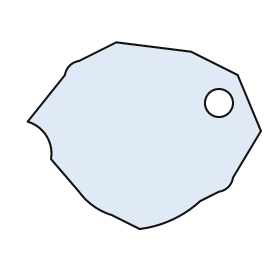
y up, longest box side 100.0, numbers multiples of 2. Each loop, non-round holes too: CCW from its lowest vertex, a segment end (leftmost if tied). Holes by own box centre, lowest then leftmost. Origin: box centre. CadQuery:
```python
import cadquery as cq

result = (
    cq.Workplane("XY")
    .moveTo(-2.0, -40.0)
    .threePointArc((12.0, -36.0), (24.0, -28.0))
    .lineTo(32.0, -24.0)
    .threePointArc((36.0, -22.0), (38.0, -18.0))
    .lineTo(50.0, 2.0)
    .lineTo(40.0, 26.0)
    .lineTo(20.0, 36.0)
    .lineTo(-12.0, 40.0)
    .lineTo(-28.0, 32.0)
    .threePointArc((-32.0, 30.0), (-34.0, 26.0))
    .lineTo(-50.0, 6.0)
    .threePointArc((-42.0, 0.0), (-40.0, -10.0))
    .lineTo(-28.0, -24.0)
    .threePointArc((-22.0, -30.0), (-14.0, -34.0))
    .close()
    .moveTo(32.0, 14.0)
    .circle(6.0)
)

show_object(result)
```